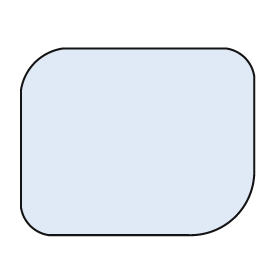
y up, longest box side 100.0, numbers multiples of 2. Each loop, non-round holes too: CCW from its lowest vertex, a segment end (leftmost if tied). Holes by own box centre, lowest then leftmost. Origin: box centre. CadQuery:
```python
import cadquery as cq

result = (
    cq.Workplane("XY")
    .moveTo(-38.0, -40.0)
    .lineTo(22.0, -40.0)
    .threePointArc((42.0, -32.0), (50.0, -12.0))
    .lineTo(50.0, 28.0)
    .threePointArc((46.0, 36.0), (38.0, 40.0))
    .lineTo(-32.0, 40.0)
    .threePointArc((-44.0, 34.0), (-50.0, 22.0))
    .lineTo(-50.0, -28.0)
    .threePointArc((-46.0, -36.0), (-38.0, -40.0))
    .close()
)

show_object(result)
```